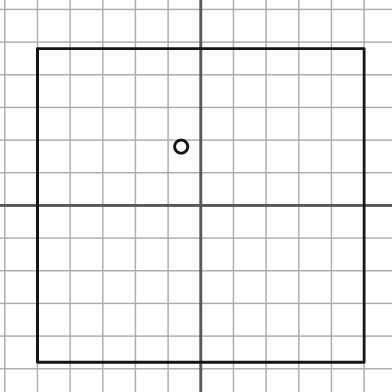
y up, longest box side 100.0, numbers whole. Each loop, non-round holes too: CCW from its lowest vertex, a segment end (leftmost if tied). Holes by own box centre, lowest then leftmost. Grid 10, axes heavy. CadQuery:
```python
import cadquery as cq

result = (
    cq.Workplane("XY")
    .moveTo(-50.0, -48.0)
    .lineTo(50.0, -48.0)
    .lineTo(50.0, 48.0)
    .lineTo(-50.0, 48.0)
    .close()
    .moveTo(-6.0, 18.0)
    .circle(2.0)
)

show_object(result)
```